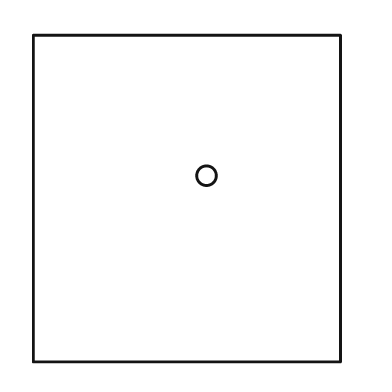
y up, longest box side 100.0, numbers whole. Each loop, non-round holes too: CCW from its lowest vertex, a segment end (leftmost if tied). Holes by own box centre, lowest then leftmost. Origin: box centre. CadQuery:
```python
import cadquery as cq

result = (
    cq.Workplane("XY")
    .moveTo(-47.0, -50.0)
    .lineTo(47.0, -50.0)
    .lineTo(47.0, 50.0)
    .lineTo(-47.0, 50.0)
    .close()
    .moveTo(6.0, 7.0)
    .circle(3.0)
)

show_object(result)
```